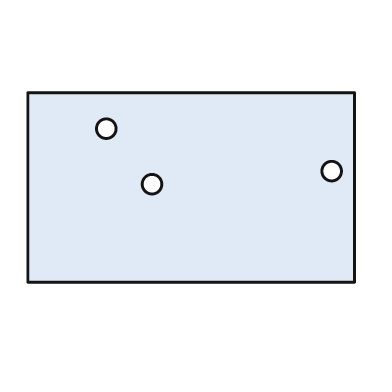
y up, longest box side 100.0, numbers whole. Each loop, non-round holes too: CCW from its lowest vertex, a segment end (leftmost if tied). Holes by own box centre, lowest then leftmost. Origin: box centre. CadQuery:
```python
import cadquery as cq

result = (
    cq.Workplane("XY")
    .moveTo(-50.0, -29.0)
    .lineTo(50.0, -29.0)
    .lineTo(50.0, 29.0)
    .lineTo(-50.0, 29.0)
    .close()
    .moveTo(-12.0, 1.0)
    .circle(3.0)
    .moveTo(43.0, 5.0)
    .circle(3.0)
    .moveTo(-26.0, 18.0)
    .circle(3.0)
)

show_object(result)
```